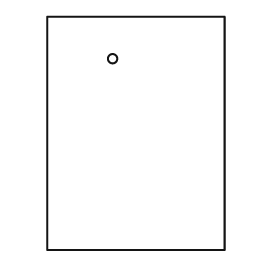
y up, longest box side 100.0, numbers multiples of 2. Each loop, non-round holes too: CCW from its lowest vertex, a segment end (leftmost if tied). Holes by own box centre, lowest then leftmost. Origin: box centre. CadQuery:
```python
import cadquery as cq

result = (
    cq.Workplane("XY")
    .moveTo(-38.0, -50.0)
    .lineTo(38.0, -50.0)
    .lineTo(38.0, 50.0)
    .lineTo(-38.0, 50.0)
    .close()
    .moveTo(-10.0, 32.0)
    .circle(2.0)
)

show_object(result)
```